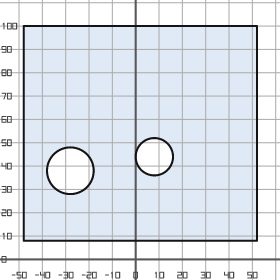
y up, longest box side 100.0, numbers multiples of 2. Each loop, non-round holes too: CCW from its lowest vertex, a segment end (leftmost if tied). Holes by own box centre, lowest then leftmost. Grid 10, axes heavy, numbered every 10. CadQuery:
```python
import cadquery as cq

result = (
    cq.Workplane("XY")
    .moveTo(-48.0, 8.0)
    .lineTo(52.0, 8.0)
    .lineTo(52.0, 100.0)
    .lineTo(-48.0, 100.0)
    .close()
    .moveTo(-28.0, 38.0)
    .circle(10.0)
    .moveTo(8.0, 44.0)
    .circle(8.0)
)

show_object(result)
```